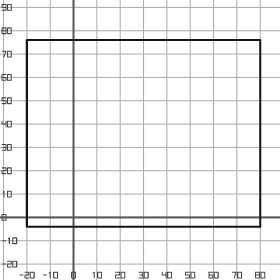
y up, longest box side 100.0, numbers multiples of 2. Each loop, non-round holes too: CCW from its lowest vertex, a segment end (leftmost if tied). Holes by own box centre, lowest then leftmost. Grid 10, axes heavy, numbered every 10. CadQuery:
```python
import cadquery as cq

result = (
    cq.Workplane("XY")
    .moveTo(-20.0, -4.0)
    .lineTo(80.0, -4.0)
    .lineTo(80.0, 76.0)
    .lineTo(-20.0, 76.0)
    .close()
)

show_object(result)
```